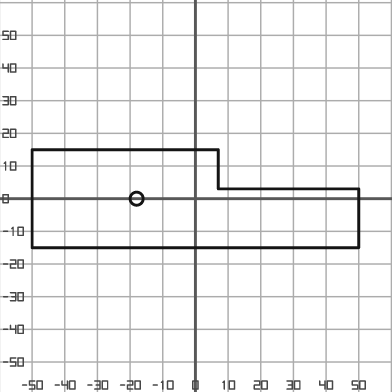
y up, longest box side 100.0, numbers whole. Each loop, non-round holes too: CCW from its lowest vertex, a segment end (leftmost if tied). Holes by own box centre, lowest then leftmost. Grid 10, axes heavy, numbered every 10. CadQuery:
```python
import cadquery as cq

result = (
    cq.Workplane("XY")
    .moveTo(-50.0, -15.0)
    .lineTo(50.0, -15.0)
    .lineTo(50.0, 3.0)
    .lineTo(7.0, 3.0)
    .lineTo(7.0, 15.0)
    .lineTo(-50.0, 15.0)
    .close()
    .moveTo(-18.0, 0.0)
    .circle(2.0)
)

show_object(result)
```